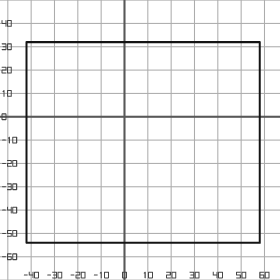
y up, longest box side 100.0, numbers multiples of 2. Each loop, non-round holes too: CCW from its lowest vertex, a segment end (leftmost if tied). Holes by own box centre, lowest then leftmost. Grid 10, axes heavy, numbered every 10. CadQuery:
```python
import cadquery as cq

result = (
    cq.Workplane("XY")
    .moveTo(-42.0, -54.0)
    .lineTo(58.0, -54.0)
    .lineTo(58.0, 32.0)
    .lineTo(-42.0, 32.0)
    .close()
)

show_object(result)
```